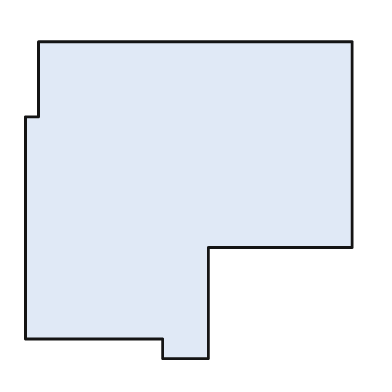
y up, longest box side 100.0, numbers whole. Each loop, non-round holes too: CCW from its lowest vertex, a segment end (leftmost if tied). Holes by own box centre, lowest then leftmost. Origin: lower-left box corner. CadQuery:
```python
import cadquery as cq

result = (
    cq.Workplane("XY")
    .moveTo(42.0, 0.0)
    .lineTo(56.0, 0.0)
    .lineTo(56.0, 34.0)
    .lineTo(100.0, 34.0)
    .lineTo(100.0, 97.0)
    .lineTo(4.0, 97.0)
    .lineTo(4.0, 74.0)
    .lineTo(0.0, 74.0)
    .lineTo(0.0, 6.0)
    .lineTo(42.0, 6.0)
    .close()
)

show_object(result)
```